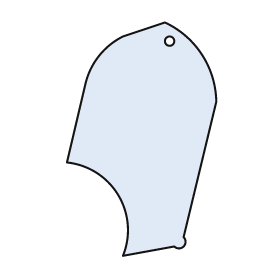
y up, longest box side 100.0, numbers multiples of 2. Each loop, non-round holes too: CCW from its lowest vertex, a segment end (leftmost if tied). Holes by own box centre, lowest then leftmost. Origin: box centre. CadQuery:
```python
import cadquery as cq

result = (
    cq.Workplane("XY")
    .moveTo(-8.0, -50.0)
    .lineTo(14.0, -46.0)
    .threePointArc((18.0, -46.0), (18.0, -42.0))
    .lineTo(32.0, 16.0)
    .threePointArc((26.0, 36.0), (10.0, 50.0))
    .lineTo(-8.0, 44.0)
    .threePointArc((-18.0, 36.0), (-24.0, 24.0))
    .lineTo(-32.0, -10.0)
    .threePointArc((-10.0, -24.0), (-8.0, -50.0))
    .close()
    .moveTo(12.0, 42.0)
    .circle(2.0)
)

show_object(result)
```